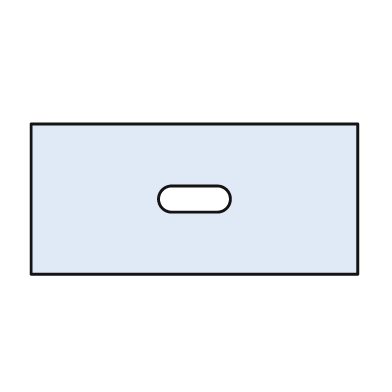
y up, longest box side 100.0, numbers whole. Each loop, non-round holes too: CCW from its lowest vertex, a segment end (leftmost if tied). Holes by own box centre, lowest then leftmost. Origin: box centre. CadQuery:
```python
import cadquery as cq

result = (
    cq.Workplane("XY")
    .moveTo(-50.0, -23.0)
    .lineTo(50.0, -23.0)
    .lineTo(50.0, 23.0)
    .lineTo(-50.0, 23.0)
    .close()
    .moveTo(-7.0, -4.0)
    .lineTo(7.0, -4.0)
    .threePointArc((11.0, 0.0), (7.0, 4.0))
    .lineTo(-7.0, 4.0)
    .threePointArc((-11.0, 0.0), (-7.0, -4.0))
    .close()
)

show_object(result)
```